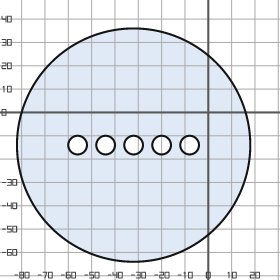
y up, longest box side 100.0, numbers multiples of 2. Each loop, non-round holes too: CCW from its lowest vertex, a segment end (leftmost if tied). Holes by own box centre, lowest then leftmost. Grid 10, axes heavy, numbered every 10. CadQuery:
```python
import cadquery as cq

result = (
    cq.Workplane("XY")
    .moveTo(-32.0, -14.0)
    .circle(50.0)
    .moveTo(-56.0, -14.0)
    .circle(4.0)
    .moveTo(-44.0, -14.0)
    .circle(4.0)
    .moveTo(-32.0, -14.0)
    .circle(4.0)
    .moveTo(-20.0, -14.0)
    .circle(4.0)
    .moveTo(-8.0, -14.0)
    .circle(4.0)
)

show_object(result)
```